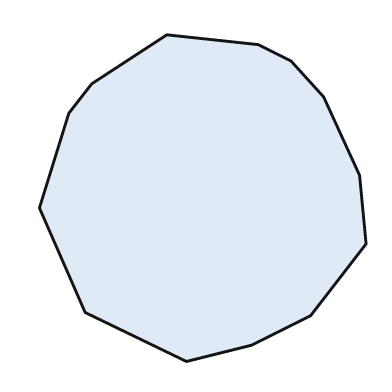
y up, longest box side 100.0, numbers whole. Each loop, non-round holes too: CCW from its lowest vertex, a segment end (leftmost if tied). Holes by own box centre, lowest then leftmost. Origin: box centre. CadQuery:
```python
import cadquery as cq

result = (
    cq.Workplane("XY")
    .moveTo(-5.0, -50.0)
    .lineTo(15.0, -45.0)
    .lineTo(33.0, -36.0)
    .lineTo(50.0, -14.0)
    .lineTo(48.0, 7.0)
    .lineTo(37.0, 31.0)
    .lineTo(27.0, 42.0)
    .lineTo(17.0, 47.0)
    .lineTo(-11.0, 50.0)
    .lineTo(-34.0, 35.0)
    .lineTo(-41.0, 26.0)
    .lineTo(-50.0, -3.0)
    .lineTo(-36.0, -35.0)
    .close()
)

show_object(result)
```